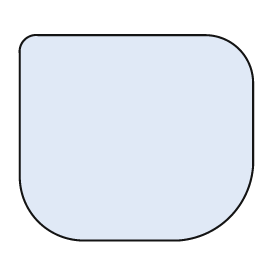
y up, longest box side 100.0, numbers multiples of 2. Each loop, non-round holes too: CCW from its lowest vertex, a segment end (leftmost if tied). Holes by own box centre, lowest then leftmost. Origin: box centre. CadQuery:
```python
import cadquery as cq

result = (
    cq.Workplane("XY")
    .moveTo(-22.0, -44.0)
    .lineTo(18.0, -44.0)
    .threePointArc((40.0, -34.0), (50.0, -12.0))
    .lineTo(50.0, 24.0)
    .threePointArc((44.0, 38.0), (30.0, 44.0))
    .lineTo(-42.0, 44.0)
    .threePointArc((-48.0, 42.0), (-50.0, 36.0))
    .lineTo(-50.0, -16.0)
    .threePointArc((-42.0, -36.0), (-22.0, -44.0))
    .close()
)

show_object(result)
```